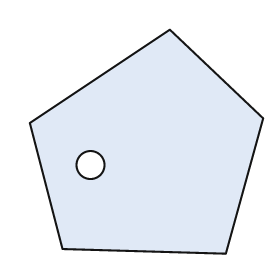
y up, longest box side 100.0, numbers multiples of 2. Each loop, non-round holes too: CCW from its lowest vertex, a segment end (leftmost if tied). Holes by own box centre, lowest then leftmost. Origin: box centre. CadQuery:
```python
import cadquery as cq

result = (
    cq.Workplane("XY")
    .moveTo(34.0, -48.0)
    .lineTo(50.0, 10.0)
    .lineTo(10.0, 48.0)
    .lineTo(-50.0, 8.0)
    .lineTo(-36.0, -46.0)
    .close()
    .moveTo(-24.0, -10.0)
    .circle(6.0)
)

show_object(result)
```